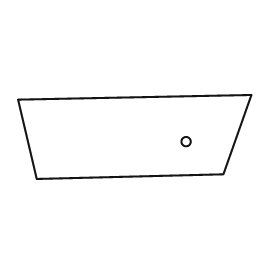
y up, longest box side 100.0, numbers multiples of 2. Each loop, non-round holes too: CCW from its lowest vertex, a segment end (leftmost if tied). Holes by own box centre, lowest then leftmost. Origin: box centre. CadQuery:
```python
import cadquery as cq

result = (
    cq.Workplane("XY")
    .moveTo(-42.0, -18.0)
    .lineTo(38.0, -16.0)
    .lineTo(50.0, 18.0)
    .lineTo(-50.0, 16.0)
    .close()
    .moveTo(22.0, -2.0)
    .circle(2.0)
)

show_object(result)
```